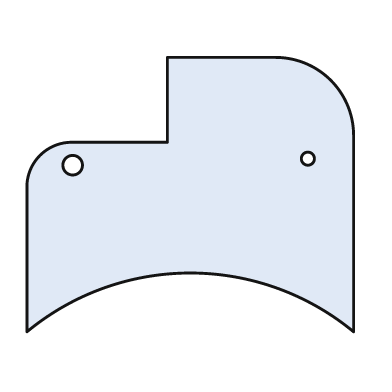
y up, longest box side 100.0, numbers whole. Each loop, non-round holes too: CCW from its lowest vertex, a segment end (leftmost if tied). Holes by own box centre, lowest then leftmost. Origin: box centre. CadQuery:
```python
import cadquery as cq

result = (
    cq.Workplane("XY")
    .moveTo(-50.0, -42.0)
    .threePointArc((0.0, -24.0), (50.0, -42.0))
    .lineTo(50.0, 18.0)
    .threePointArc((43.0, 35.0), (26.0, 42.0))
    .lineTo(-7.0, 42.0)
    .lineTo(-7.0, 16.0)
    .lineTo(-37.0, 16.0)
    .threePointArc((-46.0, 12.0), (-50.0, 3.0))
    .close()
    .moveTo(-36.0, 9.0)
    .circle(3.0)
    .moveTo(36.0, 11.0)
    .circle(2.0)
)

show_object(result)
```